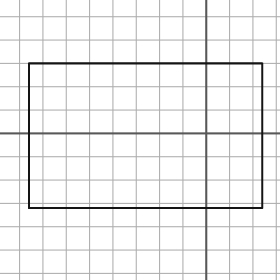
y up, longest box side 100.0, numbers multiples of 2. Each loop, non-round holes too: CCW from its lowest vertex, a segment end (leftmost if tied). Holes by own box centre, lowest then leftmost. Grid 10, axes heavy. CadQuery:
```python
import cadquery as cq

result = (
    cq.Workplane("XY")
    .moveTo(-76.0, -32.0)
    .lineTo(24.0, -32.0)
    .lineTo(24.0, 30.0)
    .lineTo(-76.0, 30.0)
    .close()
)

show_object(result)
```